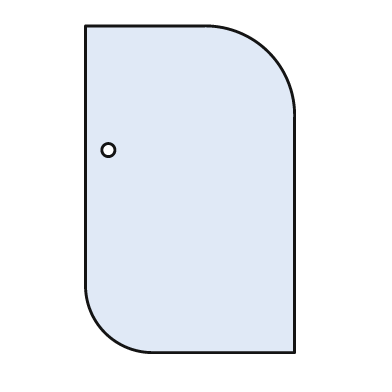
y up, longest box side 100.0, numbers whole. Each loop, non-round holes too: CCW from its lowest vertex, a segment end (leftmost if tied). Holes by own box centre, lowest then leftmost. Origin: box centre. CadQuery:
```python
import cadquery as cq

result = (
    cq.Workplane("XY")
    .moveTo(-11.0, -50.0)
    .lineTo(32.0, -50.0)
    .lineTo(32.0, 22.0)
    .threePointArc((24.0, 42.0), (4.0, 50.0))
    .lineTo(-32.0, 50.0)
    .lineTo(-32.0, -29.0)
    .threePointArc((-26.0, -44.0), (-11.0, -50.0))
    .close()
    .moveTo(-25.0, 12.0)
    .circle(2.0)
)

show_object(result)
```